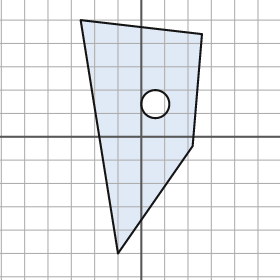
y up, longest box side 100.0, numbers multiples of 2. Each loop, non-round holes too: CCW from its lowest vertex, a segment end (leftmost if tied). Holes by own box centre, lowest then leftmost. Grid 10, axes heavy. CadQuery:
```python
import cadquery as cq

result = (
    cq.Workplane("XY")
    .moveTo(-10.0, -50.0)
    .lineTo(22.0, -4.0)
    .lineTo(26.0, 44.0)
    .lineTo(-26.0, 50.0)
    .close()
    .moveTo(6.0, 14.0)
    .circle(6.0)
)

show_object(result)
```